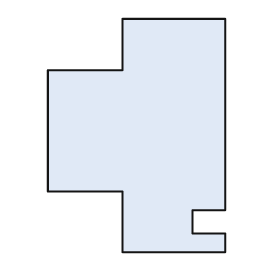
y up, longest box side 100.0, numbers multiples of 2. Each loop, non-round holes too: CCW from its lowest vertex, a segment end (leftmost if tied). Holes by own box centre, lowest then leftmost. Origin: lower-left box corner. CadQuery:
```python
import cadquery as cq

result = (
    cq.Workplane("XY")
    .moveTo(32.0, 0.0)
    .lineTo(76.0, 0.0)
    .lineTo(76.0, 8.0)
    .lineTo(62.0, 8.0)
    .lineTo(62.0, 18.0)
    .lineTo(76.0, 18.0)
    .lineTo(76.0, 100.0)
    .lineTo(32.0, 100.0)
    .lineTo(32.0, 78.0)
    .lineTo(0.0, 78.0)
    .lineTo(0.0, 26.0)
    .lineTo(32.0, 26.0)
    .close()
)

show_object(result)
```